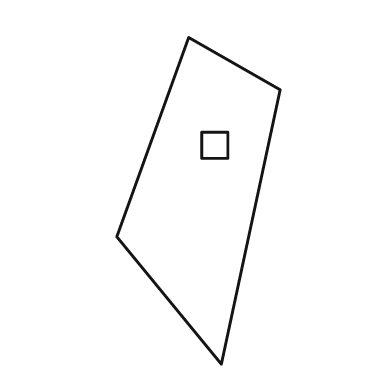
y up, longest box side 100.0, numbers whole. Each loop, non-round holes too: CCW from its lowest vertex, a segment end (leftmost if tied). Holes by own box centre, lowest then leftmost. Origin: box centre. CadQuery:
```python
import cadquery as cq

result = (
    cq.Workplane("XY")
    .moveTo(7.0, -50.0)
    .lineTo(25.0, 34.0)
    .lineTo(-3.0, 50.0)
    .lineTo(-25.0, -11.0)
    .close()
    .moveTo(1.0, 13.0)
    .lineTo(9.0, 13.0)
    .lineTo(9.0, 21.0)
    .lineTo(1.0, 21.0)
    .close()
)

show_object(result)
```